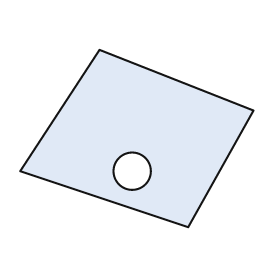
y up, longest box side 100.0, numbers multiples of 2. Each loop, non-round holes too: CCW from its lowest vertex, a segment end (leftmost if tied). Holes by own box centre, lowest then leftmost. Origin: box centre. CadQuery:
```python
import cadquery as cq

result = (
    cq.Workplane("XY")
    .moveTo(22.0, -38.0)
    .lineTo(50.0, 12.0)
    .lineTo(-16.0, 38.0)
    .lineTo(-50.0, -14.0)
    .close()
    .moveTo(-2.0, -14.0)
    .circle(8.0)
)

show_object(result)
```